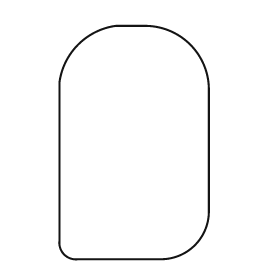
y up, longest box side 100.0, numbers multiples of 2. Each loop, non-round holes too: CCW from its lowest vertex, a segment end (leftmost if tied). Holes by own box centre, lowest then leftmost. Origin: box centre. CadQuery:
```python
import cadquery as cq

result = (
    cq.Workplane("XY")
    .moveTo(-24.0, -50.0)
    .lineTo(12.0, -50.0)
    .threePointArc((26.0, -44.0), (32.0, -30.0))
    .lineTo(32.0, 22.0)
    .threePointArc((24.0, 42.0), (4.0, 50.0))
    .lineTo(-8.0, 50.0)
    .threePointArc((-24.0, 42.0), (-32.0, 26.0))
    .lineTo(-32.0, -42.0)
    .threePointArc((-30.0, -48.0), (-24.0, -50.0))
    .close()
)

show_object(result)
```